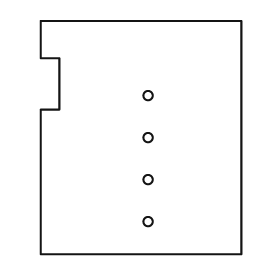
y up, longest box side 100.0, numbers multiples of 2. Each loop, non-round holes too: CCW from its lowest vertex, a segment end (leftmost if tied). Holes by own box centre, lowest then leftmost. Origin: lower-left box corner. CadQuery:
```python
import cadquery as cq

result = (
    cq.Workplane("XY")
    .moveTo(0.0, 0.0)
    .lineTo(86.0, 0.0)
    .lineTo(86.0, 100.0)
    .lineTo(0.0, 100.0)
    .lineTo(0.0, 84.0)
    .lineTo(8.0, 84.0)
    .lineTo(8.0, 62.0)
    .lineTo(0.0, 62.0)
    .close()
    .moveTo(46.0, 14.0)
    .circle(2.0)
    .moveTo(46.0, 32.0)
    .circle(2.0)
    .moveTo(46.0, 50.0)
    .circle(2.0)
    .moveTo(46.0, 68.0)
    .circle(2.0)
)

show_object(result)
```